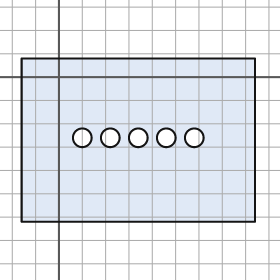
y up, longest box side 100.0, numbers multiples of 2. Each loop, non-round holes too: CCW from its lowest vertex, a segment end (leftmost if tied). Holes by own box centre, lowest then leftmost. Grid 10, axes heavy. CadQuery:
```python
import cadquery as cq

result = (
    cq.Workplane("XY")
    .moveTo(-16.0, -62.0)
    .lineTo(84.0, -62.0)
    .lineTo(84.0, 8.0)
    .lineTo(-16.0, 8.0)
    .close()
    .moveTo(10.0, -26.0)
    .circle(4.0)
    .moveTo(22.0, -26.0)
    .circle(4.0)
    .moveTo(34.0, -26.0)
    .circle(4.0)
    .moveTo(46.0, -26.0)
    .circle(4.0)
    .moveTo(58.0, -26.0)
    .circle(4.0)
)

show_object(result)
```